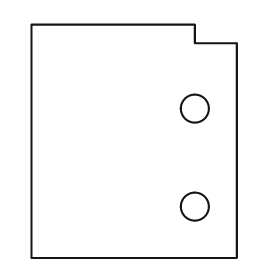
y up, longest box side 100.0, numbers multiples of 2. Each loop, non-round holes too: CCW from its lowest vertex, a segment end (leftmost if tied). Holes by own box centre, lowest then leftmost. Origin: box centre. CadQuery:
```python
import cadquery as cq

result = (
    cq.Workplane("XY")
    .moveTo(-44.0, -50.0)
    .lineTo(44.0, -50.0)
    .lineTo(44.0, 42.0)
    .lineTo(26.0, 42.0)
    .lineTo(26.0, 50.0)
    .lineTo(-44.0, 50.0)
    .close()
    .moveTo(26.0, -28.0)
    .circle(6.0)
    .moveTo(26.0, 14.0)
    .circle(6.0)
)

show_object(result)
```